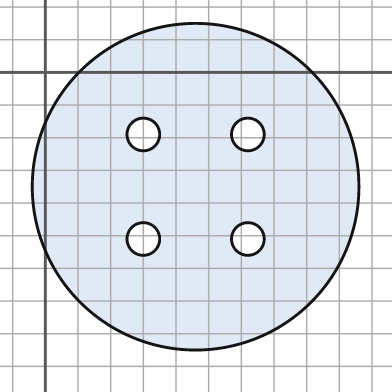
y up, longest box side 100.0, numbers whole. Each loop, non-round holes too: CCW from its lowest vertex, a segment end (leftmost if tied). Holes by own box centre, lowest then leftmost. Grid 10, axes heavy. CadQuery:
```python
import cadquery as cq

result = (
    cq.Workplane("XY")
    .moveTo(46.0, -35.0)
    .circle(50.0)
    .moveTo(30.0, -51.0)
    .circle(5.0)
    .moveTo(62.0, -51.0)
    .circle(5.0)
    .moveTo(30.0, -19.0)
    .circle(5.0)
    .moveTo(62.0, -19.0)
    .circle(5.0)
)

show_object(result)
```